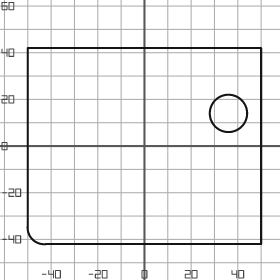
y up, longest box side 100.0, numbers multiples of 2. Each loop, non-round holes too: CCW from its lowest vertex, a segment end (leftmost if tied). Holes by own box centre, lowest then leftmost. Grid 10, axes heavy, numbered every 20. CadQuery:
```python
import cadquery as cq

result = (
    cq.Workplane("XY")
    .moveTo(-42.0, -42.0)
    .lineTo(50.0, -42.0)
    .lineTo(50.0, 42.0)
    .lineTo(-50.0, 42.0)
    .lineTo(-50.0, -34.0)
    .threePointArc((-48.0, -40.0), (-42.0, -42.0))
    .close()
    .moveTo(36.0, 14.0)
    .circle(8.0)
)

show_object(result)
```